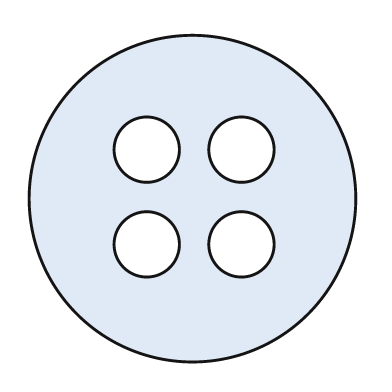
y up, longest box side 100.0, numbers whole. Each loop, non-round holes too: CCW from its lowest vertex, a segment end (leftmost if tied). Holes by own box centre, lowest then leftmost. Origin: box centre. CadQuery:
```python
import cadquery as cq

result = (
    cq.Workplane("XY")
    .moveTo(0.0, 0.0)
    .circle(50.0)
    .moveTo(-14.0, -14.0)
    .circle(10.0)
    .moveTo(15.0, -14.0)
    .circle(10.0)
    .moveTo(-14.0, 15.0)
    .circle(10.0)
    .moveTo(15.0, 15.0)
    .circle(10.0)
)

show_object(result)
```